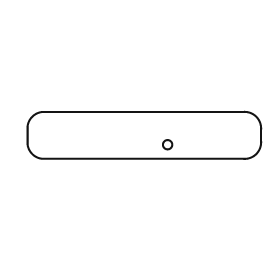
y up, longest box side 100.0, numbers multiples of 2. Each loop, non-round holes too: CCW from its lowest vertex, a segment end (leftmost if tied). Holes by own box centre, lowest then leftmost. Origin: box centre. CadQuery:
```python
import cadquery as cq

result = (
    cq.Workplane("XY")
    .moveTo(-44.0, -10.0)
    .lineTo(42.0, -10.0)
    .threePointArc((48.0, -8.0), (50.0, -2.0))
    .lineTo(50.0, 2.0)
    .threePointArc((48.0, 8.0), (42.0, 10.0))
    .lineTo(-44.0, 10.0)
    .threePointArc((-48.0, 8.0), (-50.0, 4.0))
    .lineTo(-50.0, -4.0)
    .threePointArc((-48.0, -8.0), (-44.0, -10.0))
    .close()
    .moveTo(10.0, -4.0)
    .circle(2.0)
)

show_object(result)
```